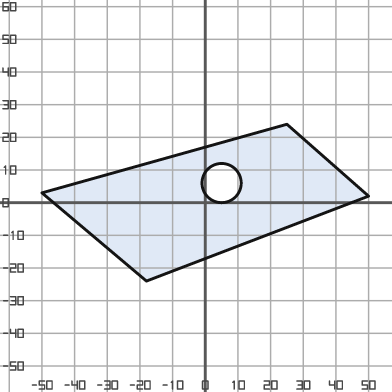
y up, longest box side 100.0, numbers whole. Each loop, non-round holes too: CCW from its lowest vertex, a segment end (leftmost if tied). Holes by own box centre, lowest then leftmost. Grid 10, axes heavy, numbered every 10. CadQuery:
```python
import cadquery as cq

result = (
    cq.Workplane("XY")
    .moveTo(-18.0, -24.0)
    .lineTo(50.0, 2.0)
    .lineTo(25.0, 24.0)
    .lineTo(-50.0, 3.0)
    .close()
    .moveTo(5.0, 6.0)
    .circle(6.0)
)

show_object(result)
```